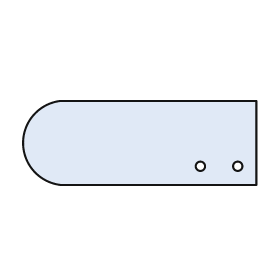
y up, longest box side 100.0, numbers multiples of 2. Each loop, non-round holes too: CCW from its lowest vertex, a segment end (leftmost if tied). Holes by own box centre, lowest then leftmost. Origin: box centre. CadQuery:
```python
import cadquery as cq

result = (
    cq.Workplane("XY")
    .moveTo(-34.0, -18.0)
    .lineTo(50.0, -18.0)
    .lineTo(50.0, 18.0)
    .lineTo(-34.0, 18.0)
    .threePointArc((-50.0, 0.0), (-34.0, -18.0))
    .close()
    .moveTo(26.0, -10.0)
    .circle(2.0)
    .moveTo(42.0, -10.0)
    .circle(2.0)
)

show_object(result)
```